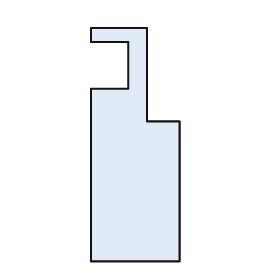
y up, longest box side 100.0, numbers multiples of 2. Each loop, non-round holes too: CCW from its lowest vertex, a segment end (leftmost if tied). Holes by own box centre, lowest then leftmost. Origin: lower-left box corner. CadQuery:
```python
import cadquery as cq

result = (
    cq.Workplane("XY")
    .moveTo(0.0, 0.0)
    .lineTo(38.0, 0.0)
    .lineTo(38.0, 60.0)
    .lineTo(24.0, 60.0)
    .lineTo(24.0, 100.0)
    .lineTo(0.0, 100.0)
    .lineTo(0.0, 94.0)
    .lineTo(16.0, 94.0)
    .lineTo(16.0, 74.0)
    .lineTo(0.0, 74.0)
    .close()
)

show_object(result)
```